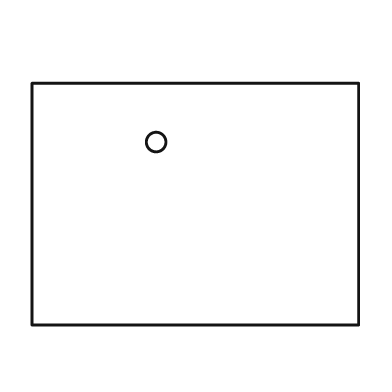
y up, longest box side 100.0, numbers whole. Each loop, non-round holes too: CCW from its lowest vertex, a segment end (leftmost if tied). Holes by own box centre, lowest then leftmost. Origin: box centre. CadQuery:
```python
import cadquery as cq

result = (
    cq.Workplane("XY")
    .moveTo(-50.0, -37.0)
    .lineTo(50.0, -37.0)
    .lineTo(50.0, 37.0)
    .lineTo(-50.0, 37.0)
    .close()
    .moveTo(-12.0, 19.0)
    .circle(3.0)
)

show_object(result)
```